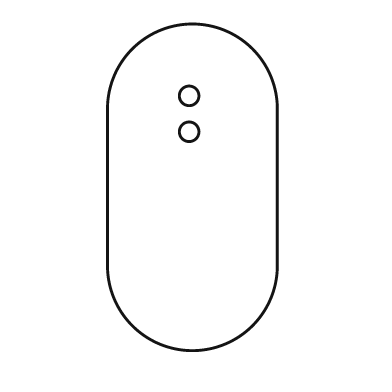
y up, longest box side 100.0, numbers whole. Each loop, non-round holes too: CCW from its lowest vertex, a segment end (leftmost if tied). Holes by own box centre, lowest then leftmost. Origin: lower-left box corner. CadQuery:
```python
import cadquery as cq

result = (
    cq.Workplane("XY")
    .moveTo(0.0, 26.0)
    .threePointArc((26.0, 0.0), (52.0, 26.0))
    .lineTo(52.0, 74.0)
    .threePointArc((26.0, 100.0), (0.0, 74.0))
    .close()
    .moveTo(25.0, 67.0)
    .circle(3.0)
    .moveTo(25.0, 78.0)
    .circle(3.0)
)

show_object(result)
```